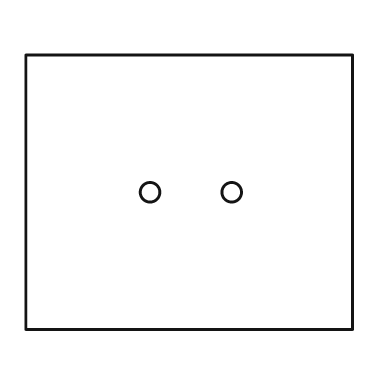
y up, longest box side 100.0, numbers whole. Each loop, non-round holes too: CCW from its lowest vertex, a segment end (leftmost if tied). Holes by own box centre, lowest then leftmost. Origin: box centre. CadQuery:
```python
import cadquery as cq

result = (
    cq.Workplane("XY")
    .moveTo(-50.0, -42.0)
    .lineTo(50.0, -42.0)
    .lineTo(50.0, 42.0)
    .lineTo(-50.0, 42.0)
    .close()
    .moveTo(-12.0, 0.0)
    .circle(3.0)
    .moveTo(13.0, 0.0)
    .circle(3.0)
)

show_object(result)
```